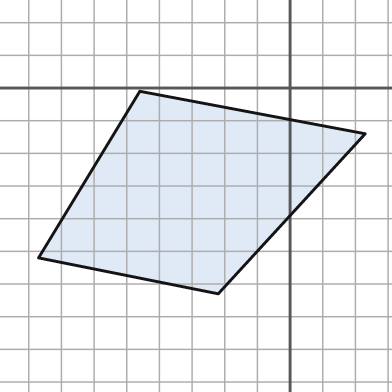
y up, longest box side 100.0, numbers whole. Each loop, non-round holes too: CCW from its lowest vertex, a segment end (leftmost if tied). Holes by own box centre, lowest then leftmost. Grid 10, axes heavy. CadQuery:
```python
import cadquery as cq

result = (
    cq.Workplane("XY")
    .moveTo(-22.0, -63.0)
    .lineTo(23.0, -14.0)
    .lineTo(-46.0, -1.0)
    .lineTo(-77.0, -52.0)
    .close()
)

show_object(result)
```